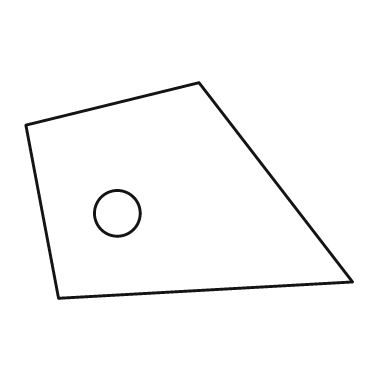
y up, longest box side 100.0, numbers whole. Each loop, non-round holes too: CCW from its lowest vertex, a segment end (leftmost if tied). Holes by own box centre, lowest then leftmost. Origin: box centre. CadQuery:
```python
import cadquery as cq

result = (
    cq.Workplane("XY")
    .moveTo(-40.0, -33.0)
    .lineTo(50.0, -28.0)
    .lineTo(3.0, 33.0)
    .lineTo(-50.0, 20.0)
    .close()
    .moveTo(-22.0, -7.0)
    .circle(7.0)
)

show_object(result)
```